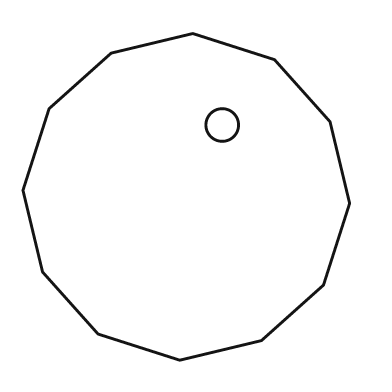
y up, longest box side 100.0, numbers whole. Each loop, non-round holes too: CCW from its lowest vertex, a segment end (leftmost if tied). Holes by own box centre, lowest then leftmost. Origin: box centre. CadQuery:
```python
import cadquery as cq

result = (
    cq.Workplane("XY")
    .moveTo(-2.0, -50.0)
    .lineTo(23.0, -44.0)
    .lineTo(42.0, -27.0)
    .lineTo(50.0, -2.0)
    .lineTo(44.0, 23.0)
    .lineTo(27.0, 42.0)
    .lineTo(2.0, 50.0)
    .lineTo(-23.0, 44.0)
    .lineTo(-42.0, 27.0)
    .lineTo(-50.0, 2.0)
    .lineTo(-44.0, -23.0)
    .lineTo(-27.0, -42.0)
    .close()
    .moveTo(11.0, 22.0)
    .circle(5.0)
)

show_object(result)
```